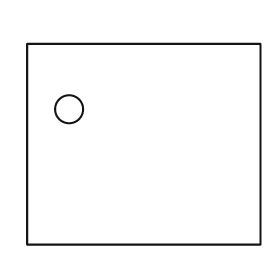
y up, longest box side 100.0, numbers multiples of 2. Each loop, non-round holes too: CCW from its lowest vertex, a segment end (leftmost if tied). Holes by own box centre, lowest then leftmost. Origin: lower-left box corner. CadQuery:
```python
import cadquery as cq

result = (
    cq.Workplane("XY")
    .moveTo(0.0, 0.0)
    .lineTo(100.0, 0.0)
    .lineTo(100.0, 86.0)
    .lineTo(0.0, 86.0)
    .close()
    .moveTo(18.0, 58.0)
    .circle(6.0)
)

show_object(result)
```